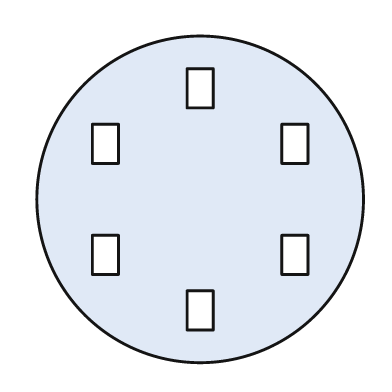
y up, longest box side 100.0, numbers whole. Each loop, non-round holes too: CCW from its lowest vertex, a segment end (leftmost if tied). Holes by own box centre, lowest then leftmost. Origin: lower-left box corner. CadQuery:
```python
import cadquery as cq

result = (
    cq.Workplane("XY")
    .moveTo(50.0, 50.0)
    .circle(50.0)
    .moveTo(46.0, 10.0)
    .lineTo(54.0, 10.0)
    .lineTo(54.0, 22.0)
    .lineTo(46.0, 22.0)
    .close()
    .moveTo(17.0, 27.0)
    .lineTo(25.0, 27.0)
    .lineTo(25.0, 39.0)
    .lineTo(17.0, 39.0)
    .close()
    .moveTo(75.0, 27.0)
    .lineTo(83.0, 27.0)
    .lineTo(83.0, 39.0)
    .lineTo(75.0, 39.0)
    .close()
    .moveTo(17.0, 61.0)
    .lineTo(25.0, 61.0)
    .lineTo(25.0, 73.0)
    .lineTo(17.0, 73.0)
    .close()
    .moveTo(75.0, 61.0)
    .lineTo(83.0, 61.0)
    .lineTo(83.0, 73.0)
    .lineTo(75.0, 73.0)
    .close()
    .moveTo(46.0, 78.0)
    .lineTo(54.0, 78.0)
    .lineTo(54.0, 90.0)
    .lineTo(46.0, 90.0)
    .close()
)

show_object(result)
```